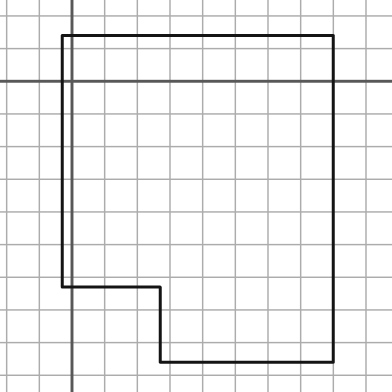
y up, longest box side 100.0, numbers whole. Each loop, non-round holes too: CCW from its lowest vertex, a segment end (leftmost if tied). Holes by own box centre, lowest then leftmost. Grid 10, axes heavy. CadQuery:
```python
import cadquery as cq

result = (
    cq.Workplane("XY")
    .moveTo(27.0, -86.0)
    .lineTo(80.0, -86.0)
    .lineTo(80.0, 14.0)
    .lineTo(-3.0, 14.0)
    .lineTo(-3.0, -63.0)
    .lineTo(27.0, -63.0)
    .close()
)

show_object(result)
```